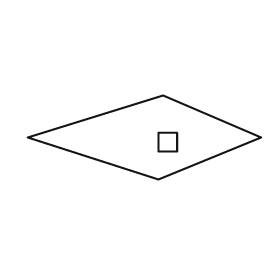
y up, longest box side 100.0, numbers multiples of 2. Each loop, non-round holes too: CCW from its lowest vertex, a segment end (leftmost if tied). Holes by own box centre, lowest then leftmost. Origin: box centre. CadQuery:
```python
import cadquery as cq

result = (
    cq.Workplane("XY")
    .moveTo(6.0, -18.0)
    .lineTo(50.0, 0.0)
    .lineTo(8.0, 18.0)
    .lineTo(-50.0, 0.0)
    .close()
    .moveTo(6.0, -6.0)
    .lineTo(14.0, -6.0)
    .lineTo(14.0, 2.0)
    .lineTo(6.0, 2.0)
    .close()
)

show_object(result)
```